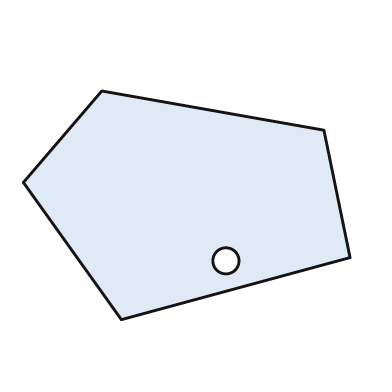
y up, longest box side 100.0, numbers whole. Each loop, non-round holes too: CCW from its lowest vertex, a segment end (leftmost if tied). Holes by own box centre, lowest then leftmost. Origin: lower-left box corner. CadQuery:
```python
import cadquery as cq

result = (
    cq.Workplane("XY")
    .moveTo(30.0, 0.0)
    .lineTo(100.0, 19.0)
    .lineTo(92.0, 58.0)
    .lineTo(24.0, 70.0)
    .lineTo(0.0, 42.0)
    .close()
    .moveTo(62.0, 18.0)
    .circle(4.0)
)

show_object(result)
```